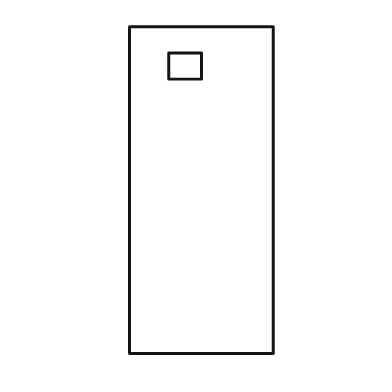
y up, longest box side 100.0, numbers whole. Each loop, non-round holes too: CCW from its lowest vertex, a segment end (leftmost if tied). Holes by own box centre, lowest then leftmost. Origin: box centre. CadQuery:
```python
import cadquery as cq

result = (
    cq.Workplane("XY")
    .moveTo(-22.0, -50.0)
    .lineTo(22.0, -50.0)
    .lineTo(22.0, 50.0)
    .lineTo(-22.0, 50.0)
    .close()
    .moveTo(-10.0, 34.0)
    .lineTo(0.0, 34.0)
    .lineTo(0.0, 42.0)
    .lineTo(-10.0, 42.0)
    .close()
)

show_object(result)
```